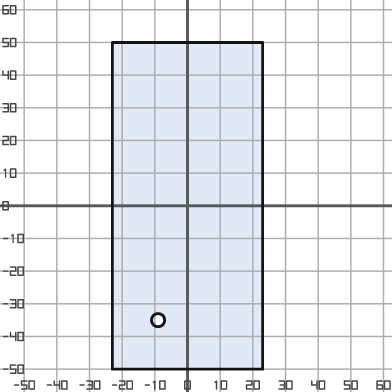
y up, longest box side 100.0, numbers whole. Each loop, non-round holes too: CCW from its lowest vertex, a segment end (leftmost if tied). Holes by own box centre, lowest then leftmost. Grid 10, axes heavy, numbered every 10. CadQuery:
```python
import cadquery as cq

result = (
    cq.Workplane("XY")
    .moveTo(-23.0, -50.0)
    .lineTo(23.0, -50.0)
    .lineTo(23.0, 50.0)
    .lineTo(-23.0, 50.0)
    .close()
    .moveTo(-9.0, -35.0)
    .circle(2.0)
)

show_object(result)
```